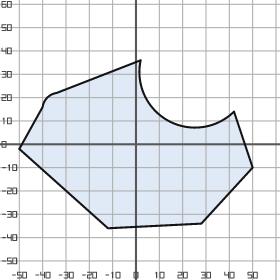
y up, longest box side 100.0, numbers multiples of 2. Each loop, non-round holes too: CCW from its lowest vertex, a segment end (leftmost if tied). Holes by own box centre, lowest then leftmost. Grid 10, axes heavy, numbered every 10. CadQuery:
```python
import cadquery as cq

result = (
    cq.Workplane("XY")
    .moveTo(-12.0, -36.0)
    .lineTo(28.0, -34.0)
    .lineTo(50.0, -10.0)
    .lineTo(42.0, 14.0)
    .threePointArc((14.0, 10.0), (2.0, 36.0))
    .lineTo(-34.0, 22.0)
    .threePointArc((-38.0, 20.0), (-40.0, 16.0))
    .lineTo(-50.0, -2.0)
    .close()
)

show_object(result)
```